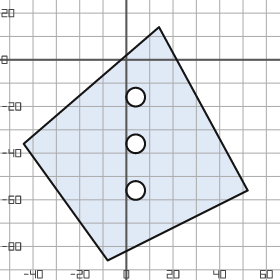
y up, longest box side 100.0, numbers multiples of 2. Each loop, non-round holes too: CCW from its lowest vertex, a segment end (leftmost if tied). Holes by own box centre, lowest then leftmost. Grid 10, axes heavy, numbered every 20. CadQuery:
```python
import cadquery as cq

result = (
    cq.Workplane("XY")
    .moveTo(-8.0, -86.0)
    .lineTo(52.0, -56.0)
    .lineTo(14.0, 14.0)
    .lineTo(-44.0, -36.0)
    .close()
    .moveTo(4.0, -56.0)
    .circle(4.0)
    .moveTo(4.0, -36.0)
    .circle(4.0)
    .moveTo(4.0, -16.0)
    .circle(4.0)
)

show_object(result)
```